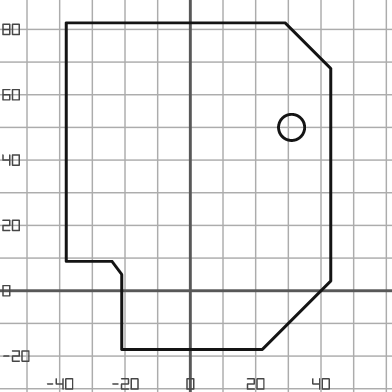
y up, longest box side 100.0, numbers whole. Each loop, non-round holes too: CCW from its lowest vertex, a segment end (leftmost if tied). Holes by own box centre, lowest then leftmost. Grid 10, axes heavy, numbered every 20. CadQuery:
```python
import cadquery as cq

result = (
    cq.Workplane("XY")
    .moveTo(-21.0, -18.0)
    .lineTo(22.0, -18.0)
    .lineTo(43.0, 3.0)
    .lineTo(43.0, 68.0)
    .lineTo(29.0, 82.0)
    .lineTo(-38.0, 82.0)
    .lineTo(-38.0, 9.0)
    .lineTo(-24.0, 9.0)
    .lineTo(-21.0, 5.0)
    .close()
    .moveTo(31.0, 50.0)
    .circle(4.0)
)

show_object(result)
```